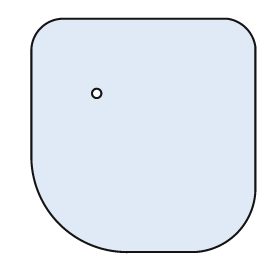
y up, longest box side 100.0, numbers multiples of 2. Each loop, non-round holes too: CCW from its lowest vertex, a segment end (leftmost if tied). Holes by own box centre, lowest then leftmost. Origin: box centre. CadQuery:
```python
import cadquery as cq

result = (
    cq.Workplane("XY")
    .moveTo(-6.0, -50.0)
    .lineTo(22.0, -50.0)
    .threePointArc((40.0, -42.0), (48.0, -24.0))
    .lineTo(48.0, 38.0)
    .threePointArc((44.0, 46.0), (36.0, 50.0))
    .lineTo(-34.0, 50.0)
    .threePointArc((-44.0, 46.0), (-48.0, 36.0))
    .lineTo(-48.0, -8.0)
    .threePointArc((-36.0, -38.0), (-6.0, -50.0))
    .close()
    .moveTo(-20.0, 18.0)
    .circle(2.0)
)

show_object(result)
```